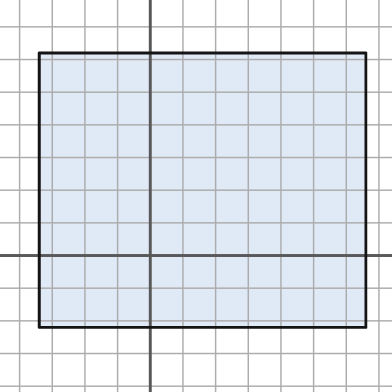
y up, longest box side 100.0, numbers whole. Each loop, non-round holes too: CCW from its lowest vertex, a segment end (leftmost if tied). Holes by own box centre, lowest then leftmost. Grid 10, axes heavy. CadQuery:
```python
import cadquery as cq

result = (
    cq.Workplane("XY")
    .moveTo(-34.0, -22.0)
    .lineTo(66.0, -22.0)
    .lineTo(66.0, 62.0)
    .lineTo(-34.0, 62.0)
    .close()
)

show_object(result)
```